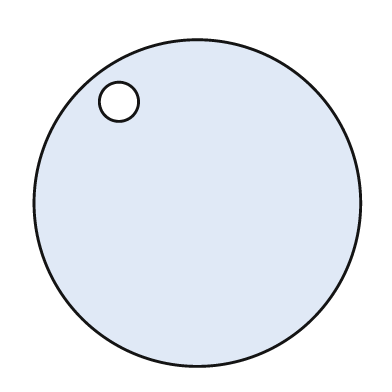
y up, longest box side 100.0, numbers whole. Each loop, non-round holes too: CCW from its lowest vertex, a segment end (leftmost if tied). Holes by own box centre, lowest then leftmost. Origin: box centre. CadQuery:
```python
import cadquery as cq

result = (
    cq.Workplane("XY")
    .moveTo(0.0, 0.0)
    .circle(50.0)
    .moveTo(-24.0, 31.0)
    .circle(6.0)
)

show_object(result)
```